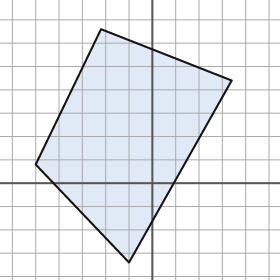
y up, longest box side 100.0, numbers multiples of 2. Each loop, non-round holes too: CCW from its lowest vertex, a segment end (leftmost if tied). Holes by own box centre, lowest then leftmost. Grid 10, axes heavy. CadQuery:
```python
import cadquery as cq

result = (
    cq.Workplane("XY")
    .moveTo(-10.0, -34.0)
    .lineTo(34.0, 44.0)
    .lineTo(-22.0, 66.0)
    .lineTo(-50.0, 8.0)
    .close()
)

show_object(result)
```